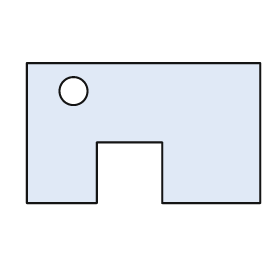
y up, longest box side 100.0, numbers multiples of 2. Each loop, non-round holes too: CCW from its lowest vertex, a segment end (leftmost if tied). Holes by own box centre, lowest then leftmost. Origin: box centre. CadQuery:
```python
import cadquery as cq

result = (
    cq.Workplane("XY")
    .moveTo(-50.0, -30.0)
    .lineTo(-20.0, -30.0)
    .lineTo(-20.0, -4.0)
    .lineTo(8.0, -4.0)
    .lineTo(8.0, -30.0)
    .lineTo(50.0, -30.0)
    .lineTo(50.0, 30.0)
    .lineTo(-50.0, 30.0)
    .close()
    .moveTo(-30.0, 18.0)
    .circle(6.0)
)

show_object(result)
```